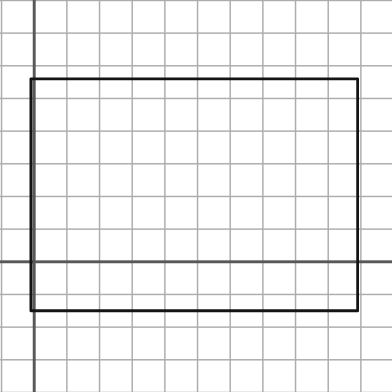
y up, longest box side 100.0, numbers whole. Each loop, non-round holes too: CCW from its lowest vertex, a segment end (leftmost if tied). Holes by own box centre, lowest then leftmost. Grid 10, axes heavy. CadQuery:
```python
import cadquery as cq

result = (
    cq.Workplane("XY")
    .moveTo(-1.0, -15.0)
    .lineTo(99.0, -15.0)
    .lineTo(99.0, 56.0)
    .lineTo(-1.0, 56.0)
    .close()
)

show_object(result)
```